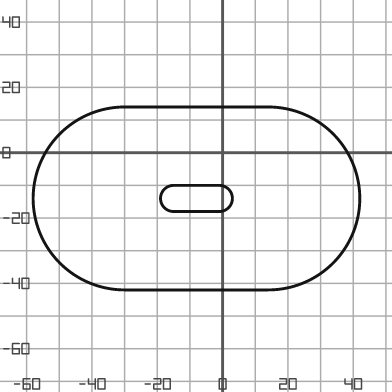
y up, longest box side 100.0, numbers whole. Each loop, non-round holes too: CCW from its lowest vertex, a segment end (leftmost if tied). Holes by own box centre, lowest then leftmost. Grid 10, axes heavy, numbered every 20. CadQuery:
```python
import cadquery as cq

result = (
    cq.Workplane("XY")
    .moveTo(-30.0, -42.0)
    .lineTo(14.0, -42.0)
    .threePointArc((42.0, -14.0), (14.0, 14.0))
    .lineTo(-30.0, 14.0)
    .threePointArc((-58.0, -14.0), (-30.0, -42.0))
    .close()
    .moveTo(-15.0, -18.0)
    .lineTo(-1.0, -18.0)
    .threePointArc((3.0, -14.0), (-1.0, -10.0))
    .lineTo(-15.0, -10.0)
    .threePointArc((-19.0, -14.0), (-15.0, -18.0))
    .close()
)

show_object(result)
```